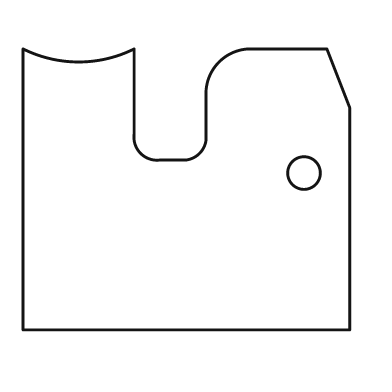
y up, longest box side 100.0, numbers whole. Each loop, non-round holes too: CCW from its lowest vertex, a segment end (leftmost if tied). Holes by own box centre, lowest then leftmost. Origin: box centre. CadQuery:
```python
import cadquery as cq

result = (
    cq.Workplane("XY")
    .moveTo(-50.0, -43.0)
    .lineTo(50.0, -43.0)
    .lineTo(50.0, 25.0)
    .lineTo(43.0, 43.0)
    .lineTo(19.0, 43.0)
    .threePointArc((10.0, 39.0), (6.0, 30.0))
    .lineTo(6.0, 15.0)
    .threePointArc((4.0, 11.0), (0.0, 9.0))
    .lineTo(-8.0, 9.0)
    .threePointArc((-14.0, 11.0), (-16.0, 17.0))
    .lineTo(-16.0, 43.0)
    .threePointArc((-33.0, 39.0), (-50.0, 43.0))
    .close()
    .moveTo(36.0, 5.0)
    .circle(5.0)
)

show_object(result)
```